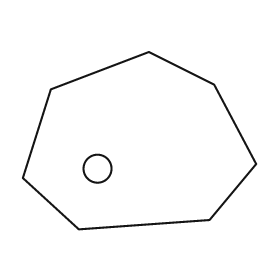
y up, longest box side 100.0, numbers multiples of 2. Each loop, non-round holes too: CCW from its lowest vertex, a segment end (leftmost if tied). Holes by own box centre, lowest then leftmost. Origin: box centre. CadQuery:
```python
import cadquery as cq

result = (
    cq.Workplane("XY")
    .moveTo(-26.0, -38.0)
    .lineTo(30.0, -34.0)
    .lineTo(50.0, -10.0)
    .lineTo(32.0, 24.0)
    .lineTo(4.0, 38.0)
    .lineTo(-38.0, 22.0)
    .lineTo(-50.0, -16.0)
    .close()
    .moveTo(-18.0, -12.0)
    .circle(6.0)
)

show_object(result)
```